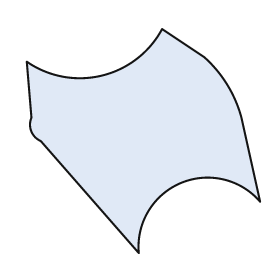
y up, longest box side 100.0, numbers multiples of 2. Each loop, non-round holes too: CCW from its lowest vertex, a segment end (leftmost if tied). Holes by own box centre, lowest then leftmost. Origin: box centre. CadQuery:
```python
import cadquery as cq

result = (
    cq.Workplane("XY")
    .moveTo(-2.0, -48.0)
    .threePointArc((16.0, -18.0), (50.0, -26.0))
    .lineTo(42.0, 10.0)
    .threePointArc((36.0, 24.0), (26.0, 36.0))
    .lineTo(8.0, 48.0)
    .threePointArc((-18.0, 28.0), (-50.0, 34.0))
    .lineTo(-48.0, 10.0)
    .threePointArc((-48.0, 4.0), (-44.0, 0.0))
    .close()
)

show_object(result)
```